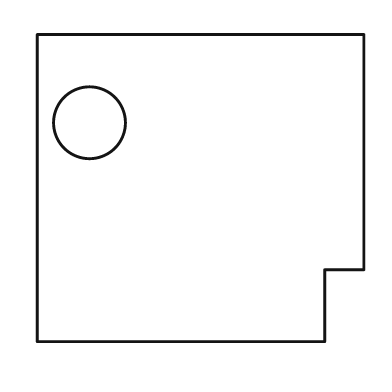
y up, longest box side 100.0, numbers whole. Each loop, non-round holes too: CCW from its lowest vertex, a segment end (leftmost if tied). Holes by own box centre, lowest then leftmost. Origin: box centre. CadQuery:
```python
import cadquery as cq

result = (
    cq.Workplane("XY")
    .moveTo(-50.0, -47.0)
    .lineTo(38.0, -47.0)
    .lineTo(38.0, -25.0)
    .lineTo(50.0, -25.0)
    .lineTo(50.0, 47.0)
    .lineTo(-50.0, 47.0)
    .close()
    .moveTo(-34.0, 20.0)
    .circle(11.0)
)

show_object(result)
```